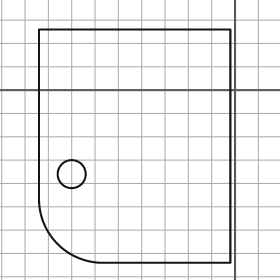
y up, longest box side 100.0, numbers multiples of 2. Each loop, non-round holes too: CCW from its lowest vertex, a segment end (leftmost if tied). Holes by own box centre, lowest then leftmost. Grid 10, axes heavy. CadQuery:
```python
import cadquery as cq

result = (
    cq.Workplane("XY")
    .moveTo(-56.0, -74.0)
    .lineTo(-2.0, -74.0)
    .lineTo(-2.0, 26.0)
    .lineTo(-84.0, 26.0)
    .lineTo(-84.0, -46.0)
    .threePointArc((-76.0, -66.0), (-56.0, -74.0))
    .close()
    .moveTo(-70.0, -36.0)
    .circle(6.0)
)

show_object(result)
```